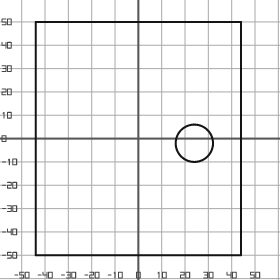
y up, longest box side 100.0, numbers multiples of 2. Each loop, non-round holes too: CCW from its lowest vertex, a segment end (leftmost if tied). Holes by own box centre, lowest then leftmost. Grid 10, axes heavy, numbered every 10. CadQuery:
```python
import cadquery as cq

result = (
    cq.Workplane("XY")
    .moveTo(-44.0, -50.0)
    .lineTo(44.0, -50.0)
    .lineTo(44.0, 50.0)
    .lineTo(-44.0, 50.0)
    .close()
    .moveTo(24.0, -2.0)
    .circle(8.0)
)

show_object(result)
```